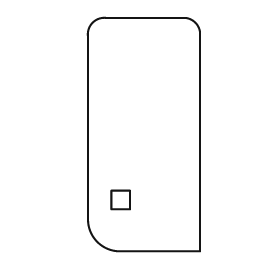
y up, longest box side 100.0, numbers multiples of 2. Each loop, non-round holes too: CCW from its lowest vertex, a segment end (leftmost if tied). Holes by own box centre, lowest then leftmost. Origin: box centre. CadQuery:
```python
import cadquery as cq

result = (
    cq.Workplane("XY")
    .moveTo(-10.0, -50.0)
    .lineTo(24.0, -50.0)
    .lineTo(24.0, 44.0)
    .threePointArc((22.0, 48.0), (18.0, 50.0))
    .lineTo(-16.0, 50.0)
    .threePointArc((-22.0, 48.0), (-24.0, 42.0))
    .lineTo(-24.0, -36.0)
    .threePointArc((-20.0, -46.0), (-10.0, -50.0))
    .close()
    .moveTo(-14.0, -32.0)
    .lineTo(-6.0, -32.0)
    .lineTo(-6.0, -24.0)
    .lineTo(-14.0, -24.0)
    .close()
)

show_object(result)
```